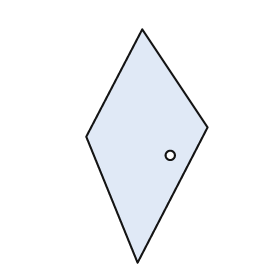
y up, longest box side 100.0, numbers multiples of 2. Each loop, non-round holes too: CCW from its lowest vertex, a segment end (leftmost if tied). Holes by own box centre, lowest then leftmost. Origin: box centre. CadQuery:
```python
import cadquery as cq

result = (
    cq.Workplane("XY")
    .moveTo(-4.0, -50.0)
    .lineTo(26.0, 8.0)
    .lineTo(-2.0, 50.0)
    .lineTo(-26.0, 4.0)
    .close()
    .moveTo(10.0, -4.0)
    .circle(2.0)
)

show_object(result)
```